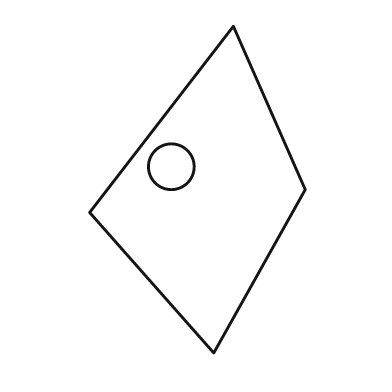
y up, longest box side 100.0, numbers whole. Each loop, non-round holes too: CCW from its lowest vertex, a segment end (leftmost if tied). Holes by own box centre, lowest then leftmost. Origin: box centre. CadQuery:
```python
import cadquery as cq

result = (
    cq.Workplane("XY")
    .moveTo(5.0, -50.0)
    .lineTo(33.0, 0.0)
    .lineTo(11.0, 50.0)
    .lineTo(-33.0, -7.0)
    .close()
    .moveTo(-8.0, 7.0)
    .circle(7.0)
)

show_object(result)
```